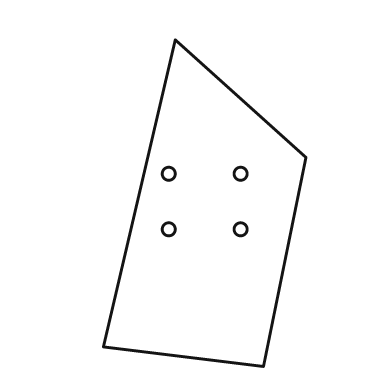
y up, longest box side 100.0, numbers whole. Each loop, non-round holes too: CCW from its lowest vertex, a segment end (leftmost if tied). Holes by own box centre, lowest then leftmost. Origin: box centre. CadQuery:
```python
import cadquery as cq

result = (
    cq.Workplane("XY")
    .moveTo(18.0, -50.0)
    .lineTo(31.0, 14.0)
    .lineTo(-9.0, 50.0)
    .lineTo(-31.0, -44.0)
    .close()
    .moveTo(-11.0, -8.0)
    .circle(2.0)
    .moveTo(11.0, -8.0)
    .circle(2.0)
    .moveTo(-11.0, 9.0)
    .circle(2.0)
    .moveTo(11.0, 9.0)
    .circle(2.0)
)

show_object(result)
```